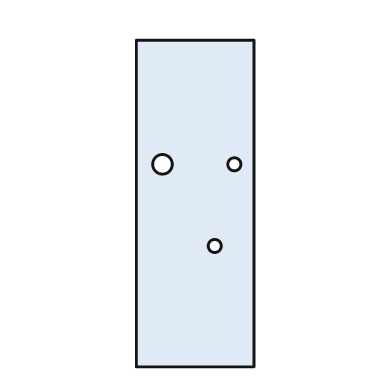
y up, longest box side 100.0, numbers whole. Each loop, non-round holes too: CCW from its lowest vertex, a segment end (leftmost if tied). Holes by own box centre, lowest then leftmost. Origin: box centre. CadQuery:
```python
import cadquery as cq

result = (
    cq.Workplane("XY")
    .moveTo(-18.0, -50.0)
    .lineTo(18.0, -50.0)
    .lineTo(18.0, 50.0)
    .lineTo(-18.0, 50.0)
    .close()
    .moveTo(6.0, -13.0)
    .circle(2.0)
    .moveTo(-10.0, 12.0)
    .circle(3.0)
    .moveTo(12.0, 12.0)
    .circle(2.0)
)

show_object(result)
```